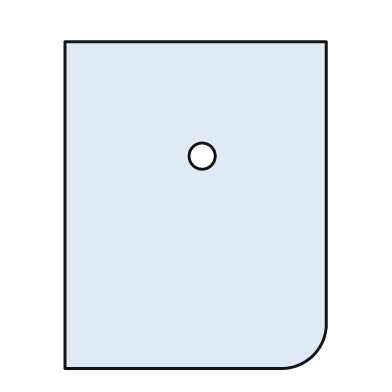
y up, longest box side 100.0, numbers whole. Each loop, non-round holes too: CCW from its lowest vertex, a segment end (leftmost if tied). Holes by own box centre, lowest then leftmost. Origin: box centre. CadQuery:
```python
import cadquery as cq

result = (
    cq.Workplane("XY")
    .moveTo(-40.0, -50.0)
    .lineTo(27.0, -50.0)
    .threePointArc((36.0, -46.0), (40.0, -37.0))
    .lineTo(40.0, 50.0)
    .lineTo(-40.0, 50.0)
    .close()
    .moveTo(2.0, 15.0)
    .circle(4.0)
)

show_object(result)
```